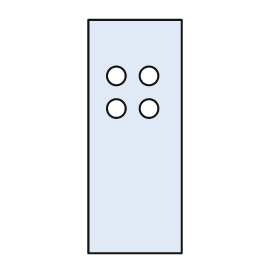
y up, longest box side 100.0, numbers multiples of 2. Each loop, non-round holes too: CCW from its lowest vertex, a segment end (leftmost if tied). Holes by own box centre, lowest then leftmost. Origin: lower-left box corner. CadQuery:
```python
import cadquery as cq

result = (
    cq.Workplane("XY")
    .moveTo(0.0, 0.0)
    .lineTo(40.0, 0.0)
    .lineTo(40.0, 100.0)
    .lineTo(0.0, 100.0)
    .close()
    .moveTo(12.0, 62.0)
    .circle(4.0)
    .moveTo(26.0, 62.0)
    .circle(4.0)
    .moveTo(12.0, 76.0)
    .circle(4.0)
    .moveTo(26.0, 76.0)
    .circle(4.0)
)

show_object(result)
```